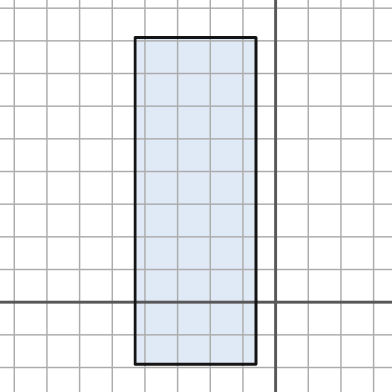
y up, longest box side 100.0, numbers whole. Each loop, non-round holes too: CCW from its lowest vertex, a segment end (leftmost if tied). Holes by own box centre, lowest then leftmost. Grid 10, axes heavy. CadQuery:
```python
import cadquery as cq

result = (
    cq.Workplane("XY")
    .moveTo(-43.0, -19.0)
    .lineTo(-6.0, -19.0)
    .lineTo(-6.0, 81.0)
    .lineTo(-43.0, 81.0)
    .close()
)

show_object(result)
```